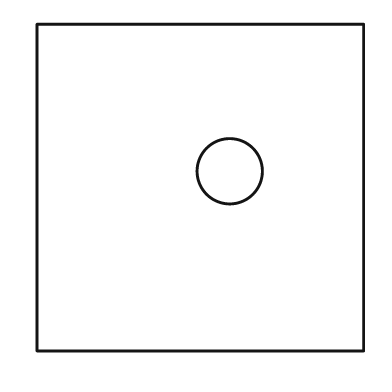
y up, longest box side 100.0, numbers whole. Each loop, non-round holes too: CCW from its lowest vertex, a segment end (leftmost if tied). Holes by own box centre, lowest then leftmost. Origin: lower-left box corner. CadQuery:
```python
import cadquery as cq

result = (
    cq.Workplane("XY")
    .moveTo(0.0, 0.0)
    .lineTo(100.0, 0.0)
    .lineTo(100.0, 100.0)
    .lineTo(0.0, 100.0)
    .close()
    .moveTo(59.0, 55.0)
    .circle(10.0)
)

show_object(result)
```